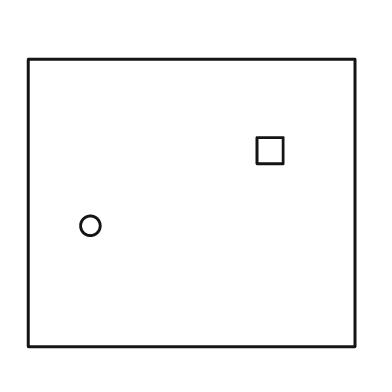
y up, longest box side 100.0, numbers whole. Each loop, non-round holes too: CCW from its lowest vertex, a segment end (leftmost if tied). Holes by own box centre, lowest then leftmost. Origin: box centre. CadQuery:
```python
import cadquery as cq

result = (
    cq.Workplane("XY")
    .moveTo(-50.0, -44.0)
    .lineTo(50.0, -44.0)
    .lineTo(50.0, 44.0)
    .lineTo(-50.0, 44.0)
    .close()
    .moveTo(-31.0, -7.0)
    .circle(3.0)
    .moveTo(20.0, 12.0)
    .lineTo(28.0, 12.0)
    .lineTo(28.0, 20.0)
    .lineTo(20.0, 20.0)
    .close()
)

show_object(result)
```